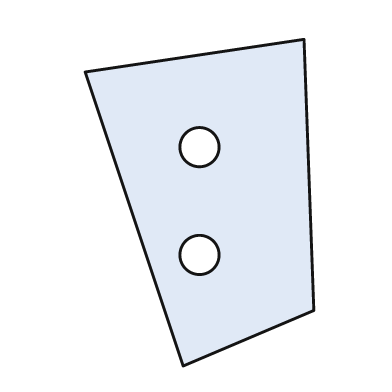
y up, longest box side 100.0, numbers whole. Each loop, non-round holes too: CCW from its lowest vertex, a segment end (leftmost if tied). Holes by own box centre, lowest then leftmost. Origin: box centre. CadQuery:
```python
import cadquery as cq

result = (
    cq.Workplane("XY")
    .moveTo(-5.0, -50.0)
    .lineTo(35.0, -33.0)
    .lineTo(32.0, 50.0)
    .lineTo(-35.0, 40.0)
    .close()
    .moveTo(0.0, -16.0)
    .circle(6.0)
    .moveTo(0.0, 17.0)
    .circle(6.0)
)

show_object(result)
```